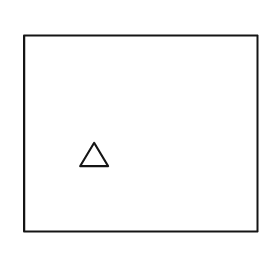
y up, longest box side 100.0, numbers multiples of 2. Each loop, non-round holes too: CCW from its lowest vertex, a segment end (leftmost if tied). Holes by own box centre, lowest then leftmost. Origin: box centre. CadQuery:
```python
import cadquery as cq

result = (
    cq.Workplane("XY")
    .moveTo(-50.0, -42.0)
    .lineTo(50.0, -42.0)
    .lineTo(50.0, 42.0)
    .lineTo(-50.0, 42.0)
    .close()
    .moveTo(-26.0, -14.0)
    .lineTo(-14.0, -14.0)
    .lineTo(-20.0, -4.0)
    .close()
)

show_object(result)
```